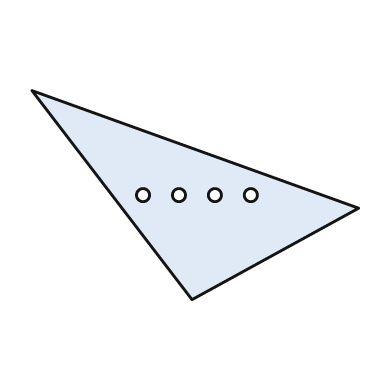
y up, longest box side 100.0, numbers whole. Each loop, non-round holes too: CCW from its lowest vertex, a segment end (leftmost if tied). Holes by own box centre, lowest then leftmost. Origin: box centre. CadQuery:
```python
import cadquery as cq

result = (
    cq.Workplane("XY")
    .moveTo(-1.0, -32.0)
    .lineTo(50.0, -4.0)
    .lineTo(-50.0, 32.0)
    .close()
    .moveTo(-16.0, 0.0)
    .circle(2.0)
    .moveTo(-5.0, 0.0)
    .circle(2.0)
    .moveTo(6.0, 0.0)
    .circle(2.0)
    .moveTo(17.0, 0.0)
    .circle(2.0)
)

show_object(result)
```